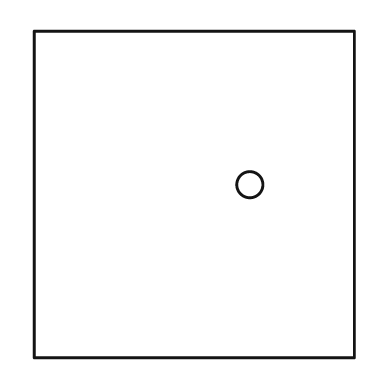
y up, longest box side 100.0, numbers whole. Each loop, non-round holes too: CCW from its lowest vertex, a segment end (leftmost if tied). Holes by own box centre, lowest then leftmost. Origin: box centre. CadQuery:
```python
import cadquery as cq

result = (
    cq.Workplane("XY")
    .moveTo(-49.0, -50.0)
    .lineTo(49.0, -50.0)
    .lineTo(49.0, 50.0)
    .lineTo(-49.0, 50.0)
    .close()
    .moveTo(17.0, 3.0)
    .circle(4.0)
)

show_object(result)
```